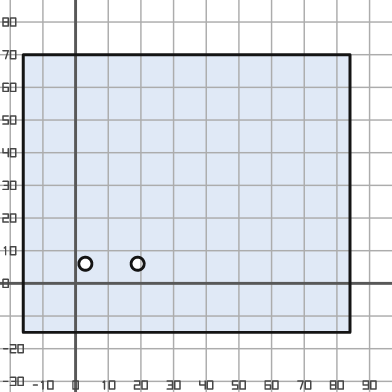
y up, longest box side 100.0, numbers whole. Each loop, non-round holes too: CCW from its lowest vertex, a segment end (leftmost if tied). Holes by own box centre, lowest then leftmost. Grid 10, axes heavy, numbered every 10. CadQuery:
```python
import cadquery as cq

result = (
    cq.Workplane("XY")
    .moveTo(-16.0, -15.0)
    .lineTo(84.0, -15.0)
    .lineTo(84.0, 70.0)
    .lineTo(-16.0, 70.0)
    .close()
    .moveTo(3.0, 6.0)
    .circle(2.0)
    .moveTo(19.0, 6.0)
    .circle(2.0)
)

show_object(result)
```